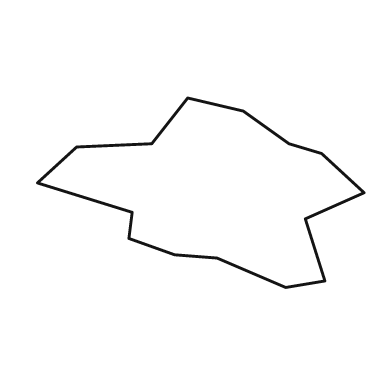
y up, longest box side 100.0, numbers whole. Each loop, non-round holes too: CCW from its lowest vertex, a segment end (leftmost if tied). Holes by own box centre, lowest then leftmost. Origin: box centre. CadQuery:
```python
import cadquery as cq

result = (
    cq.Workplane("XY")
    .moveTo(26.0, -29.0)
    .lineTo(38.0, -27.0)
    .lineTo(32.0, -8.0)
    .lineTo(50.0, 0.0)
    .lineTo(37.0, 12.0)
    .lineTo(27.0, 15.0)
    .lineTo(13.0, 25.0)
    .lineTo(-4.0, 29.0)
    .lineTo(-15.0, 15.0)
    .lineTo(-38.0, 14.0)
    .lineTo(-50.0, 3.0)
    .lineTo(-21.0, -6.0)
    .lineTo(-22.0, -14.0)
    .lineTo(-8.0, -19.0)
    .lineTo(5.0, -20.0)
    .close()
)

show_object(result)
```